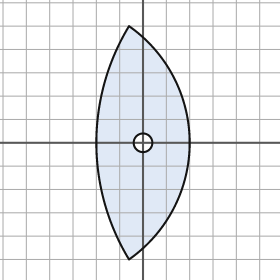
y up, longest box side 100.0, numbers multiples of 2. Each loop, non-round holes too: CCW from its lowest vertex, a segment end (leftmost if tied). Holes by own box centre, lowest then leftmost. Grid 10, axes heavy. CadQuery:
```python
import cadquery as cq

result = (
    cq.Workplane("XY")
    .moveTo(-6.0, -50.0)
    .threePointArc((20.0, 0.0), (-6.0, 50.0))
    .threePointArc((-20.0, 0.0), (-6.0, -50.0))
    .close()
    .moveTo(0.0, 0.0)
    .circle(4.0)
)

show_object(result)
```